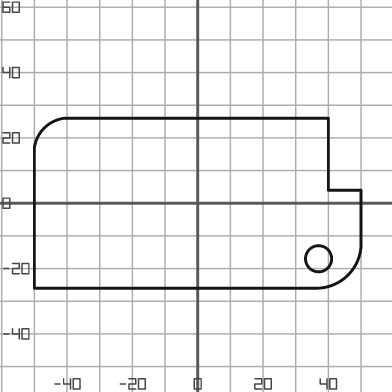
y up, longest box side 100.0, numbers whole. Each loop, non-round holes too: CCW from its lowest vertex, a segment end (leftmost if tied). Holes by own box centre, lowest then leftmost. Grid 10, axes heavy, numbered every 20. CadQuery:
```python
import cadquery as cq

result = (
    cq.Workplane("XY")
    .moveTo(-50.0, -26.0)
    .lineTo(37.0, -26.0)
    .threePointArc((46.0, -22.0), (50.0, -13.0))
    .lineTo(50.0, 4.0)
    .lineTo(40.0, 4.0)
    .lineTo(40.0, 26.0)
    .lineTo(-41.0, 26.0)
    .threePointArc((-47.0, 23.0), (-50.0, 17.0))
    .close()
    .moveTo(37.0, -17.0)
    .circle(4.0)
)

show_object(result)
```